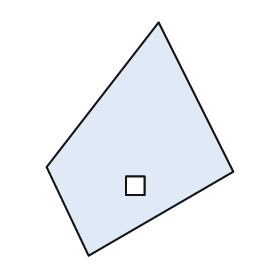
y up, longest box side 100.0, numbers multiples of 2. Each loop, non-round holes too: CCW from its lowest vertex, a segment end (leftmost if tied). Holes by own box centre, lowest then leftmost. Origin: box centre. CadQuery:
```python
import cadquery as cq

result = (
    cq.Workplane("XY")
    .moveTo(-22.0, -50.0)
    .lineTo(40.0, -14.0)
    .lineTo(8.0, 50.0)
    .lineTo(-40.0, -12.0)
    .close()
    .moveTo(-6.0, -24.0)
    .lineTo(2.0, -24.0)
    .lineTo(2.0, -16.0)
    .lineTo(-6.0, -16.0)
    .close()
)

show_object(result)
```